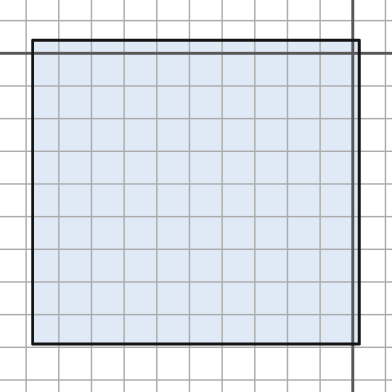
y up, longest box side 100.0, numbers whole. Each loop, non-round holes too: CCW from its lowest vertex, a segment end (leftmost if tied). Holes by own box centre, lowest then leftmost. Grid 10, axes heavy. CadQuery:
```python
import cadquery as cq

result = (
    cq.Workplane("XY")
    .moveTo(-98.0, -89.0)
    .lineTo(2.0, -89.0)
    .lineTo(2.0, 4.0)
    .lineTo(-98.0, 4.0)
    .close()
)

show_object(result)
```